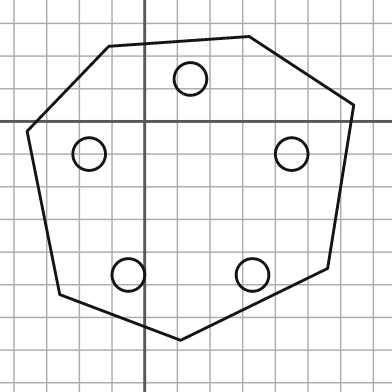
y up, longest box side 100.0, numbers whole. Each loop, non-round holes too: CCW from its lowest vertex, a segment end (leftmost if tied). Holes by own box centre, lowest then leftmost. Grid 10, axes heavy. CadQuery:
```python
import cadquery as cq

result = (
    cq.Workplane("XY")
    .moveTo(11.0, -67.0)
    .lineTo(56.0, -45.0)
    .lineTo(64.0, 5.0)
    .lineTo(32.0, 26.0)
    .lineTo(-11.0, 23.0)
    .lineTo(-36.0, -3.0)
    .lineTo(-26.0, -53.0)
    .close()
    .moveTo(-5.0, -47.0)
    .circle(5.0)
    .moveTo(33.0, -47.0)
    .circle(5.0)
    .moveTo(-17.0, -10.0)
    .circle(5.0)
    .moveTo(45.0, -10.0)
    .circle(5.0)
    .moveTo(14.0, 13.0)
    .circle(5.0)
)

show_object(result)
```